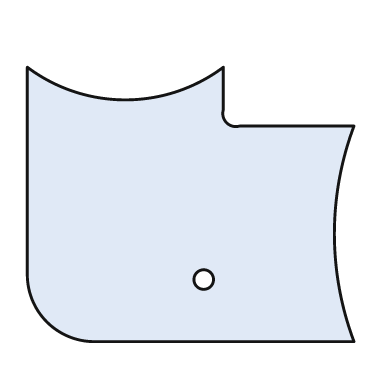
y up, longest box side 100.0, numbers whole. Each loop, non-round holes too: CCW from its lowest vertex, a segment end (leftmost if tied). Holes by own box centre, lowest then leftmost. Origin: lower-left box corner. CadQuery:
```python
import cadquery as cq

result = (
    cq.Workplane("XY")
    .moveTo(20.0, 0.0)
    .lineTo(100.0, 0.0)
    .threePointArc((94.0, 33.0), (100.0, 66.0))
    .lineTo(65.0, 66.0)
    .threePointArc((61.0, 67.0), (60.0, 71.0))
    .lineTo(60.0, 84.0)
    .threePointArc((30.0, 74.0), (0.0, 84.0))
    .lineTo(0.0, 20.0)
    .threePointArc((6.0, 6.0), (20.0, 0.0))
    .close()
    .moveTo(54.0, 19.0)
    .circle(3.0)
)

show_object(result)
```